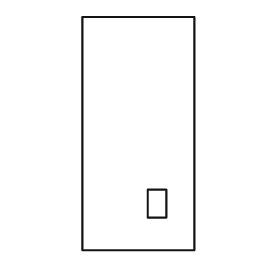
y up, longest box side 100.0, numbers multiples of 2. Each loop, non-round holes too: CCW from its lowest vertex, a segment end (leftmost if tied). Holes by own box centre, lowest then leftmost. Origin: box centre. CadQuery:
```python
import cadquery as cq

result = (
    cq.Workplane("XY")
    .moveTo(-24.0, -50.0)
    .lineTo(24.0, -50.0)
    .lineTo(24.0, 50.0)
    .lineTo(-24.0, 50.0)
    .close()
    .moveTo(4.0, -36.0)
    .lineTo(12.0, -36.0)
    .lineTo(12.0, -24.0)
    .lineTo(4.0, -24.0)
    .close()
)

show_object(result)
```